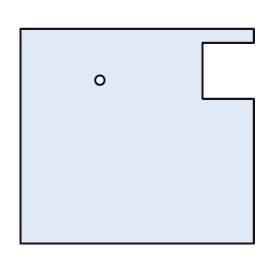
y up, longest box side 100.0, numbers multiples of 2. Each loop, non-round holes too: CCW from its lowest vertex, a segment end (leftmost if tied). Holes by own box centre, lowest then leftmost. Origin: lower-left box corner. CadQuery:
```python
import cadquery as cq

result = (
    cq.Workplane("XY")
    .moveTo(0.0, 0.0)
    .lineTo(100.0, 0.0)
    .lineTo(100.0, 62.0)
    .lineTo(78.0, 62.0)
    .lineTo(78.0, 86.0)
    .lineTo(100.0, 86.0)
    .lineTo(100.0, 92.0)
    .lineTo(0.0, 92.0)
    .close()
    .moveTo(34.0, 70.0)
    .circle(2.0)
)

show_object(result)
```